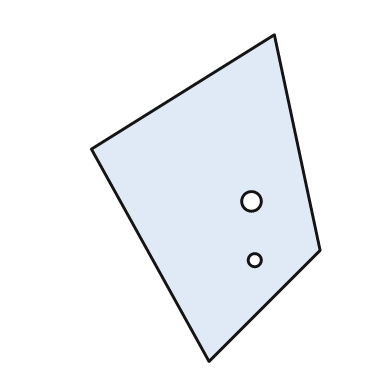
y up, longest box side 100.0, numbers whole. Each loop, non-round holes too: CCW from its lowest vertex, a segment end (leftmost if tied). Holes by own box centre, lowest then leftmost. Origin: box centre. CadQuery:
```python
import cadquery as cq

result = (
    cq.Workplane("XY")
    .moveTo(1.0, -50.0)
    .lineTo(35.0, -16.0)
    .lineTo(21.0, 50.0)
    .lineTo(-35.0, 15.0)
    .close()
    .moveTo(15.0, -19.0)
    .circle(2.0)
    .moveTo(14.0, -1.0)
    .circle(3.0)
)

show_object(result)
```